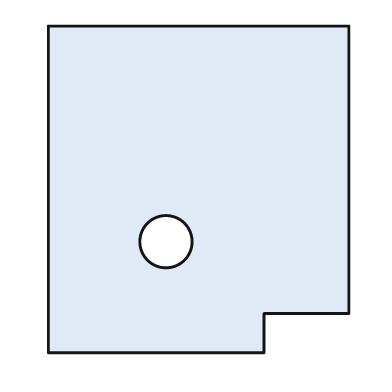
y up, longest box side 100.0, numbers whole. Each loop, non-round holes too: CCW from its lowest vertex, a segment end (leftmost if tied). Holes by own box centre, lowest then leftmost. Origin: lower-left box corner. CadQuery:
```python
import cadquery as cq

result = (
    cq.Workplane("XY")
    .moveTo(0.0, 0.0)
    .lineTo(66.0, 0.0)
    .lineTo(66.0, 12.0)
    .lineTo(92.0, 12.0)
    .lineTo(92.0, 100.0)
    .lineTo(0.0, 100.0)
    .close()
    .moveTo(36.0, 34.0)
    .circle(8.0)
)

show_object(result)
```